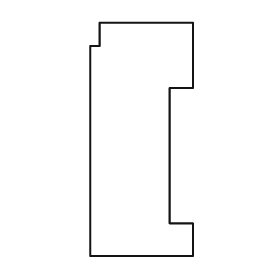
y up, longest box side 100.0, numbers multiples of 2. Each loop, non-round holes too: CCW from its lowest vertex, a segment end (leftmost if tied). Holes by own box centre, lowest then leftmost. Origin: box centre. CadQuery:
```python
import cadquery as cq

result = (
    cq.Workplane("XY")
    .moveTo(-22.0, -50.0)
    .lineTo(22.0, -50.0)
    .lineTo(22.0, -36.0)
    .lineTo(12.0, -36.0)
    .lineTo(12.0, 22.0)
    .lineTo(22.0, 22.0)
    .lineTo(22.0, 50.0)
    .lineTo(-18.0, 50.0)
    .lineTo(-18.0, 40.0)
    .lineTo(-22.0, 40.0)
    .close()
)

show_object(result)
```